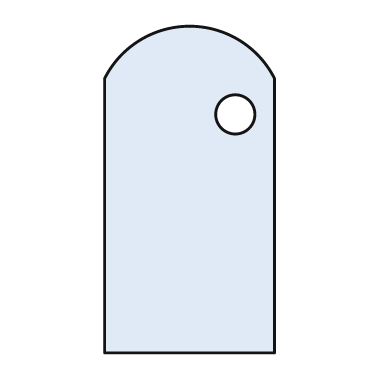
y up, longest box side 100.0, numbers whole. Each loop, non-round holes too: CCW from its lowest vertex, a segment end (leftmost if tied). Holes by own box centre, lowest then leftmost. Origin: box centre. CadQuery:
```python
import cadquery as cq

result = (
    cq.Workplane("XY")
    .moveTo(-26.0, -50.0)
    .lineTo(26.0, -50.0)
    .lineTo(26.0, 34.0)
    .threePointArc((0.0, 50.0), (-26.0, 34.0))
    .close()
    .moveTo(14.0, 23.0)
    .circle(6.0)
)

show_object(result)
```